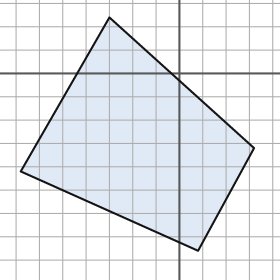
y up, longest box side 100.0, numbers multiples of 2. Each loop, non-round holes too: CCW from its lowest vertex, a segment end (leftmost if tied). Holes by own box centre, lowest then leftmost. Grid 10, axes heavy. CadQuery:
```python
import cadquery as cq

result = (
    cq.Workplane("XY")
    .moveTo(8.0, -76.0)
    .lineTo(32.0, -32.0)
    .lineTo(-30.0, 24.0)
    .lineTo(-68.0, -42.0)
    .close()
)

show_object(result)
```